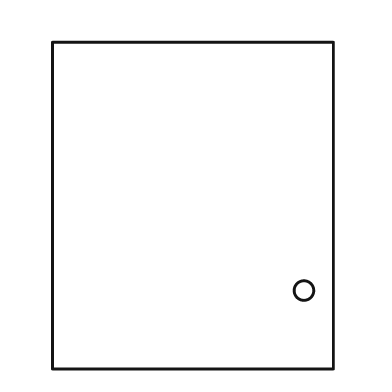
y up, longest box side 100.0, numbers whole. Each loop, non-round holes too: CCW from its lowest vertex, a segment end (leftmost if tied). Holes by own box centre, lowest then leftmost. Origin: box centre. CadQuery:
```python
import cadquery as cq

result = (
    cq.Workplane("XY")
    .moveTo(-43.0, -50.0)
    .lineTo(43.0, -50.0)
    .lineTo(43.0, 50.0)
    .lineTo(-43.0, 50.0)
    .close()
    .moveTo(34.0, -26.0)
    .circle(3.0)
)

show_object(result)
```